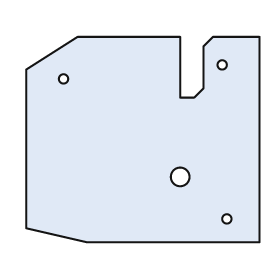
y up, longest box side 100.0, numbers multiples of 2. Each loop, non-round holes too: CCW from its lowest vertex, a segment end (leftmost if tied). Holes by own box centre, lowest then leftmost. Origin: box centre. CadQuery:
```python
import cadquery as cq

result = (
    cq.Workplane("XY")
    .moveTo(-24.0, -44.0)
    .lineTo(50.0, -44.0)
    .lineTo(50.0, 44.0)
    .lineTo(30.0, 44.0)
    .lineTo(26.0, 40.0)
    .lineTo(26.0, 22.0)
    .lineTo(22.0, 18.0)
    .lineTo(16.0, 18.0)
    .lineTo(16.0, 44.0)
    .lineTo(-28.0, 44.0)
    .lineTo(-50.0, 30.0)
    .lineTo(-50.0, -38.0)
    .close()
    .moveTo(36.0, -34.0)
    .circle(2.0)
    .moveTo(16.0, -16.0)
    .circle(4.0)
    .moveTo(-34.0, 26.0)
    .circle(2.0)
    .moveTo(34.0, 32.0)
    .circle(2.0)
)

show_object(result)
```